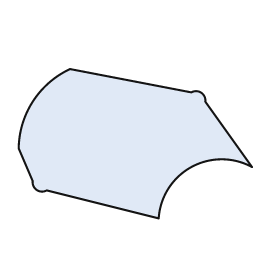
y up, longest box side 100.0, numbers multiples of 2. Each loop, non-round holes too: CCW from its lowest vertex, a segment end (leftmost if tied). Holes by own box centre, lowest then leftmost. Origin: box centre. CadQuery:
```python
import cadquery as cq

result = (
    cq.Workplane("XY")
    .moveTo(10.0, -32.0)
    .threePointArc((24.0, -10.0), (50.0, -10.0))
    .lineTo(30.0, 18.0)
    .threePointArc((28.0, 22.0), (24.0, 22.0))
    .lineTo(-28.0, 32.0)
    .threePointArc((-44.0, 18.0), (-50.0, -2.0))
    .lineTo(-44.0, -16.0)
    .threePointArc((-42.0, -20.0), (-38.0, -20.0))
    .close()
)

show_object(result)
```